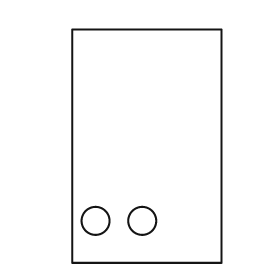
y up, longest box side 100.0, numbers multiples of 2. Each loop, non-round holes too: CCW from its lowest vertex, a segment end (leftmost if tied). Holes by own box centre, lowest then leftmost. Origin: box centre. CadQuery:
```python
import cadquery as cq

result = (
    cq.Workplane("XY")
    .moveTo(-32.0, -50.0)
    .lineTo(32.0, -50.0)
    .lineTo(32.0, 50.0)
    .lineTo(-32.0, 50.0)
    .close()
    .moveTo(-22.0, -32.0)
    .circle(6.0)
    .moveTo(-2.0, -32.0)
    .circle(6.0)
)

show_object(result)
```